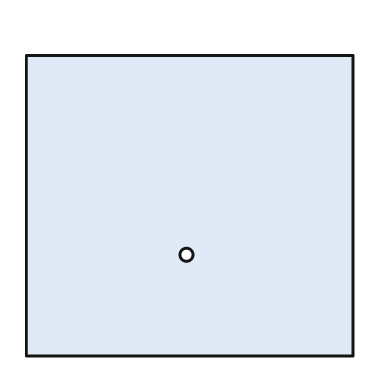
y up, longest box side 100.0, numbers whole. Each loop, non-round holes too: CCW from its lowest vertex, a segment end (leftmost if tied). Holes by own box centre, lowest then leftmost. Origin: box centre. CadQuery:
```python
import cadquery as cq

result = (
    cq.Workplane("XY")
    .moveTo(-50.0, -46.0)
    .lineTo(50.0, -46.0)
    .lineTo(50.0, 46.0)
    .lineTo(-50.0, 46.0)
    .close()
    .moveTo(-1.0, -15.0)
    .circle(2.0)
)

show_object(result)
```